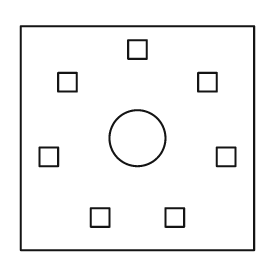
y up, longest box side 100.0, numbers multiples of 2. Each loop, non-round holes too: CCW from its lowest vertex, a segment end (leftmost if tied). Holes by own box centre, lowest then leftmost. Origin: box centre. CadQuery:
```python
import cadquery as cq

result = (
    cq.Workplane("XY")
    .moveTo(-50.0, -48.0)
    .lineTo(50.0, -48.0)
    .lineTo(50.0, 48.0)
    .lineTo(-50.0, 48.0)
    .close()
    .moveTo(-20.0, -38.0)
    .lineTo(-12.0, -38.0)
    .lineTo(-12.0, -30.0)
    .lineTo(-20.0, -30.0)
    .close()
    .moveTo(12.0, -38.0)
    .lineTo(20.0, -38.0)
    .lineTo(20.0, -30.0)
    .lineTo(12.0, -30.0)
    .close()
    .moveTo(-42.0, -12.0)
    .lineTo(-34.0, -12.0)
    .lineTo(-34.0, -4.0)
    .lineTo(-42.0, -4.0)
    .close()
    .moveTo(34.0, -12.0)
    .lineTo(42.0, -12.0)
    .lineTo(42.0, -4.0)
    .lineTo(34.0, -4.0)
    .close()
    .moveTo(0.0, 0.0)
    .circle(12.0)
    .moveTo(-34.0, 20.0)
    .lineTo(-26.0, 20.0)
    .lineTo(-26.0, 28.0)
    .lineTo(-34.0, 28.0)
    .close()
    .moveTo(26.0, 20.0)
    .lineTo(34.0, 20.0)
    .lineTo(34.0, 28.0)
    .lineTo(26.0, 28.0)
    .close()
    .moveTo(-4.0, 34.0)
    .lineTo(4.0, 34.0)
    .lineTo(4.0, 42.0)
    .lineTo(-4.0, 42.0)
    .close()
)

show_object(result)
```